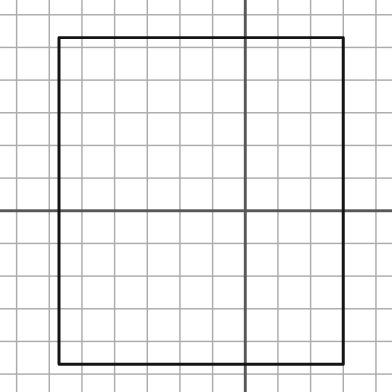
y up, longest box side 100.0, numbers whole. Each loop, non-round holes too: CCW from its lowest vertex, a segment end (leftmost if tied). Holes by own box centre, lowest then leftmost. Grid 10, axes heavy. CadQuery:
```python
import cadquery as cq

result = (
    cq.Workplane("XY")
    .moveTo(-57.0, -47.0)
    .lineTo(30.0, -47.0)
    .lineTo(30.0, 53.0)
    .lineTo(-57.0, 53.0)
    .close()
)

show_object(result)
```